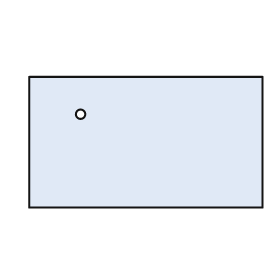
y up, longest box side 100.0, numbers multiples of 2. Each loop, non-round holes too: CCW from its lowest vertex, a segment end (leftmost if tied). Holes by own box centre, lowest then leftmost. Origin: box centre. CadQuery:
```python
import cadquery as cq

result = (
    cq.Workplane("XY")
    .moveTo(-50.0, -28.0)
    .lineTo(50.0, -28.0)
    .lineTo(50.0, 28.0)
    .lineTo(-50.0, 28.0)
    .close()
    .moveTo(-28.0, 12.0)
    .circle(2.0)
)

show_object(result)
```